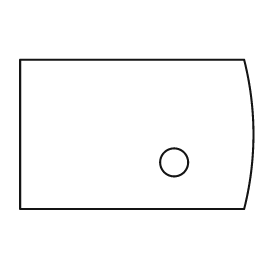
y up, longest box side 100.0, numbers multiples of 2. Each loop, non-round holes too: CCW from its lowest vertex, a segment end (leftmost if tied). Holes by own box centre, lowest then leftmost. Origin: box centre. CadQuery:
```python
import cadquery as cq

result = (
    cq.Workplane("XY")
    .moveTo(-50.0, -32.0)
    .lineTo(46.0, -32.0)
    .threePointArc((50.0, 0.0), (46.0, 32.0))
    .lineTo(-50.0, 32.0)
    .close()
    .moveTo(16.0, -12.0)
    .circle(6.0)
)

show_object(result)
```